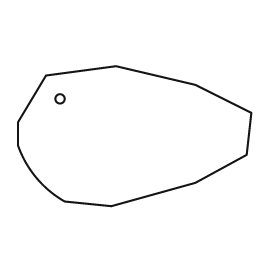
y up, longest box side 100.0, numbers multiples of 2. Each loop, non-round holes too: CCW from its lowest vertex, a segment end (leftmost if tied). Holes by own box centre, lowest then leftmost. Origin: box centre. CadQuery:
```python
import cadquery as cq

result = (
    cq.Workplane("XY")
    .moveTo(-10.0, -30.0)
    .lineTo(26.0, -20.0)
    .lineTo(48.0, -8.0)
    .lineTo(50.0, 10.0)
    .lineTo(26.0, 22.0)
    .lineTo(-8.0, 30.0)
    .lineTo(-38.0, 26.0)
    .lineTo(-50.0, 6.0)
    .lineTo(-50.0, -4.0)
    .threePointArc((-42.0, -18.0), (-30.0, -28.0))
    .close()
    .moveTo(-32.0, 16.0)
    .circle(2.0)
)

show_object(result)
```